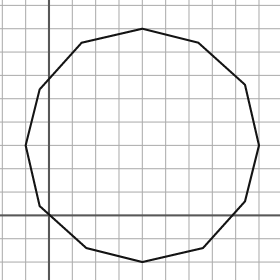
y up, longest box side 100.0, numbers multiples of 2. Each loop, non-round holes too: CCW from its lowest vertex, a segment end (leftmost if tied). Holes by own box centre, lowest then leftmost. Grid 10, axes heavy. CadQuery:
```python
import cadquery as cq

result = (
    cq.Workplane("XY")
    .moveTo(40.0, -20.0)
    .lineTo(66.0, -14.0)
    .lineTo(84.0, 6.0)
    .lineTo(90.0, 30.0)
    .lineTo(84.0, 56.0)
    .lineTo(64.0, 74.0)
    .lineTo(40.0, 80.0)
    .lineTo(14.0, 74.0)
    .lineTo(-4.0, 54.0)
    .lineTo(-10.0, 30.0)
    .lineTo(-4.0, 4.0)
    .lineTo(16.0, -14.0)
    .close()
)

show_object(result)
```